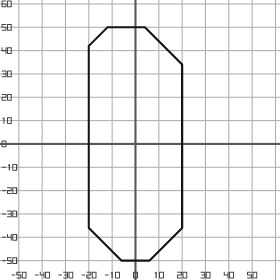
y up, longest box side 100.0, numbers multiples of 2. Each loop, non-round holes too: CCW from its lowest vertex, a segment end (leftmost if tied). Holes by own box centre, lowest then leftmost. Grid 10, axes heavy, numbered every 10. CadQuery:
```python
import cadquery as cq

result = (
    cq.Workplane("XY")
    .moveTo(-6.0, -50.0)
    .lineTo(6.0, -50.0)
    .lineTo(20.0, -36.0)
    .lineTo(20.0, 34.0)
    .lineTo(4.0, 50.0)
    .lineTo(-12.0, 50.0)
    .lineTo(-20.0, 42.0)
    .lineTo(-20.0, -36.0)
    .close()
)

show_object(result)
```